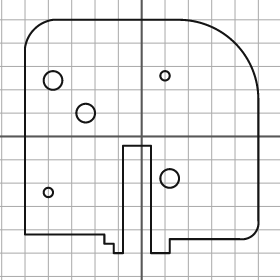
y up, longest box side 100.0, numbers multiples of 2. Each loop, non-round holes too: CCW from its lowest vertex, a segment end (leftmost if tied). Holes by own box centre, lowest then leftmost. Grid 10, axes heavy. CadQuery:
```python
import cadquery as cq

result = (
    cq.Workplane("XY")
    .moveTo(-12.0, -50.0)
    .lineTo(-8.0, -50.0)
    .lineTo(-8.0, -4.0)
    .lineTo(4.0, -4.0)
    .lineTo(4.0, -50.0)
    .lineTo(12.0, -50.0)
    .lineTo(12.0, -44.0)
    .lineTo(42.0, -44.0)
    .threePointArc((48.0, -42.0), (50.0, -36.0))
    .lineTo(50.0, 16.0)
    .threePointArc((40.0, 40.0), (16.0, 50.0))
    .lineTo(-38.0, 50.0)
    .threePointArc((-46.0, 46.0), (-50.0, 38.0))
    .lineTo(-50.0, -42.0)
    .lineTo(-16.0, -42.0)
    .lineTo(-16.0, -46.0)
    .lineTo(-12.0, -46.0)
    .close()
    .moveTo(-40.0, -24.0)
    .circle(2.0)
    .moveTo(12.0, -18.0)
    .circle(4.0)
    .moveTo(-24.0, 10.0)
    .circle(4.0)
    .moveTo(-38.0, 24.0)
    .circle(4.0)
    .moveTo(10.0, 26.0)
    .circle(2.0)
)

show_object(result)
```